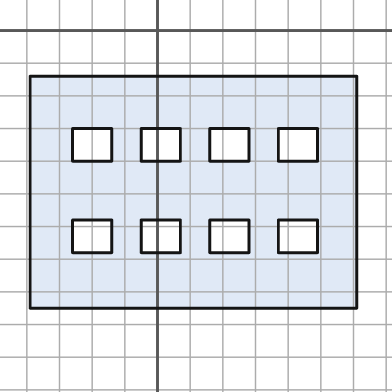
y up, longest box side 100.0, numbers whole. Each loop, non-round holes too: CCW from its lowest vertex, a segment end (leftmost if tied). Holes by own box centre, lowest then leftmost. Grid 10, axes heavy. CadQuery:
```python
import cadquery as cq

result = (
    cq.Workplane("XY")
    .moveTo(-39.0, -85.0)
    .lineTo(61.0, -85.0)
    .lineTo(61.0, -14.0)
    .lineTo(-39.0, -14.0)
    .close()
    .moveTo(-26.0, -68.0)
    .lineTo(-14.0, -68.0)
    .lineTo(-14.0, -58.0)
    .lineTo(-26.0, -58.0)
    .close()
    .moveTo(-5.0, -68.0)
    .lineTo(7.0, -68.0)
    .lineTo(7.0, -58.0)
    .lineTo(-5.0, -58.0)
    .close()
    .moveTo(16.0, -68.0)
    .lineTo(28.0, -68.0)
    .lineTo(28.0, -58.0)
    .lineTo(16.0, -58.0)
    .close()
    .moveTo(37.0, -68.0)
    .lineTo(49.0, -68.0)
    .lineTo(49.0, -58.0)
    .lineTo(37.0, -58.0)
    .close()
    .moveTo(-26.0, -40.0)
    .lineTo(-14.0, -40.0)
    .lineTo(-14.0, -30.0)
    .lineTo(-26.0, -30.0)
    .close()
    .moveTo(-5.0, -40.0)
    .lineTo(7.0, -40.0)
    .lineTo(7.0, -30.0)
    .lineTo(-5.0, -30.0)
    .close()
    .moveTo(16.0, -40.0)
    .lineTo(28.0, -40.0)
    .lineTo(28.0, -30.0)
    .lineTo(16.0, -30.0)
    .close()
    .moveTo(37.0, -40.0)
    .lineTo(49.0, -40.0)
    .lineTo(49.0, -30.0)
    .lineTo(37.0, -30.0)
    .close()
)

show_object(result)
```